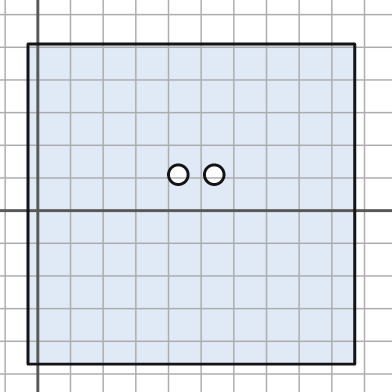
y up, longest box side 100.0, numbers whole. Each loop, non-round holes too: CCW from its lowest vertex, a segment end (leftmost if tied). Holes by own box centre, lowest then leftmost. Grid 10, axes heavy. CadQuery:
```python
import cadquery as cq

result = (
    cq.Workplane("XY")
    .moveTo(-3.0, -47.0)
    .lineTo(97.0, -47.0)
    .lineTo(97.0, 51.0)
    .lineTo(-3.0, 51.0)
    .close()
    .moveTo(43.0, 11.0)
    .circle(3.0)
    .moveTo(54.0, 11.0)
    .circle(3.0)
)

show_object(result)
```